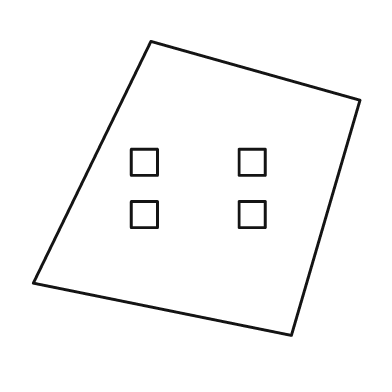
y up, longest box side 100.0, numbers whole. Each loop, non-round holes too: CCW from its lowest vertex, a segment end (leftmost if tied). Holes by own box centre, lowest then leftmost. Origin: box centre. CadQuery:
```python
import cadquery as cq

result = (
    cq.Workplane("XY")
    .moveTo(29.0, -45.0)
    .lineTo(50.0, 27.0)
    .lineTo(-14.0, 45.0)
    .lineTo(-50.0, -29.0)
    .close()
    .moveTo(-20.0, -12.0)
    .lineTo(-12.0, -12.0)
    .lineTo(-12.0, -4.0)
    .lineTo(-20.0, -4.0)
    .close()
    .moveTo(13.0, -12.0)
    .lineTo(21.0, -12.0)
    .lineTo(21.0, -4.0)
    .lineTo(13.0, -4.0)
    .close()
    .moveTo(-20.0, 4.0)
    .lineTo(-12.0, 4.0)
    .lineTo(-12.0, 12.0)
    .lineTo(-20.0, 12.0)
    .close()
    .moveTo(13.0, 4.0)
    .lineTo(21.0, 4.0)
    .lineTo(21.0, 12.0)
    .lineTo(13.0, 12.0)
    .close()
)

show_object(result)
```